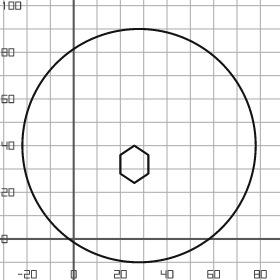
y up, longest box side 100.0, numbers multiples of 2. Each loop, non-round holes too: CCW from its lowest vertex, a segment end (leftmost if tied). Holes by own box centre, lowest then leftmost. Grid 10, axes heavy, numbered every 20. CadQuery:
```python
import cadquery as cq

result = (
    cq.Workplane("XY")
    .moveTo(28.0, 40.0)
    .circle(50.0)
    .moveTo(26.0, 24.0)
    .lineTo(32.0, 28.0)
    .lineTo(32.0, 36.0)
    .lineTo(26.0, 40.0)
    .lineTo(20.0, 36.0)
    .lineTo(20.0, 28.0)
    .close()
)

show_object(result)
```